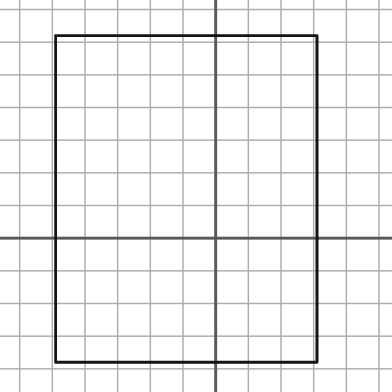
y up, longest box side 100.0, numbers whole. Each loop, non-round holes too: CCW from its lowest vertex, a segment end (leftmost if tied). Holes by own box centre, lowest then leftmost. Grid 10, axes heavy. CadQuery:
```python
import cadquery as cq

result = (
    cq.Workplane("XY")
    .moveTo(-49.0, -38.0)
    .lineTo(31.0, -38.0)
    .lineTo(31.0, 62.0)
    .lineTo(-49.0, 62.0)
    .close()
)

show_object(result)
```